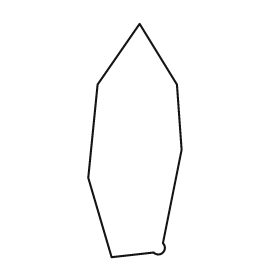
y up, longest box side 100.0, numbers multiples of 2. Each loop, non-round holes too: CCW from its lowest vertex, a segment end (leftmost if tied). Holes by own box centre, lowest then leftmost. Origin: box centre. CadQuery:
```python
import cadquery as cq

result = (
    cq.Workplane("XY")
    .moveTo(-10.0, -50.0)
    .lineTo(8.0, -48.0)
    .threePointArc((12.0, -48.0), (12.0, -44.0))
    .lineTo(20.0, -4.0)
    .lineTo(18.0, 24.0)
    .lineTo(2.0, 50.0)
    .lineTo(-16.0, 24.0)
    .lineTo(-20.0, -16.0)
    .close()
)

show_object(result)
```